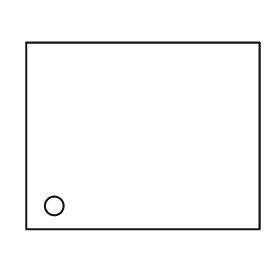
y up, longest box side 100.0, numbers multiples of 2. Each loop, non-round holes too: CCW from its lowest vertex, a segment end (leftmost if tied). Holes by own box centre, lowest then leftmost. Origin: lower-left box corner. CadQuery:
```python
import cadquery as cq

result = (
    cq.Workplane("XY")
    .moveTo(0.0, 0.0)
    .lineTo(100.0, 0.0)
    .lineTo(100.0, 80.0)
    .lineTo(0.0, 80.0)
    .close()
    .moveTo(12.0, 10.0)
    .circle(4.0)
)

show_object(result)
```